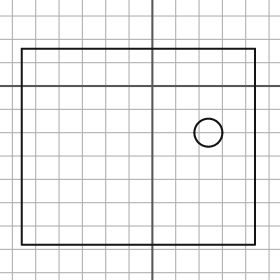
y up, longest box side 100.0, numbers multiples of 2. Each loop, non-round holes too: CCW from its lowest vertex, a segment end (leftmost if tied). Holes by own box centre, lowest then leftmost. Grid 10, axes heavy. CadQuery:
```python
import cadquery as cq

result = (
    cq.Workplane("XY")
    .moveTo(-56.0, -68.0)
    .lineTo(44.0, -68.0)
    .lineTo(44.0, 16.0)
    .lineTo(-56.0, 16.0)
    .close()
    .moveTo(24.0, -20.0)
    .circle(6.0)
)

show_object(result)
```